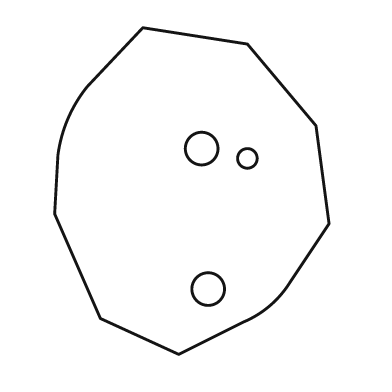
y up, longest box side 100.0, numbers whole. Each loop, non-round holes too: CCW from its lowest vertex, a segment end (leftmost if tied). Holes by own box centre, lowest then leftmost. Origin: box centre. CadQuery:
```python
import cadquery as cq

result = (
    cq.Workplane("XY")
    .moveTo(-4.0, -50.0)
    .lineTo(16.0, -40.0)
    .threePointArc((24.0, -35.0), (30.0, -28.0))
    .lineTo(42.0, -10.0)
    .lineTo(38.0, 20.0)
    .lineTo(17.0, 45.0)
    .lineTo(-15.0, 50.0)
    .lineTo(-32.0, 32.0)
    .threePointArc((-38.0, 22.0), (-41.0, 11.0))
    .lineTo(-42.0, -7.0)
    .lineTo(-28.0, -39.0)
    .close()
    .moveTo(5.0, -30.0)
    .circle(5.0)
    .moveTo(17.0, 10.0)
    .circle(3.0)
    .moveTo(3.0, 13.0)
    .circle(5.0)
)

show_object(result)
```